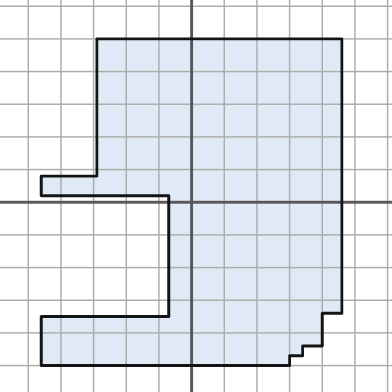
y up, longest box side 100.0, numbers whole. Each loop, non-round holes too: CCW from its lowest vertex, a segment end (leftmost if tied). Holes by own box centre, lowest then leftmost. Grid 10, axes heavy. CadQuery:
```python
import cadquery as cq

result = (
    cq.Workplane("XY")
    .moveTo(-46.0, -50.0)
    .lineTo(30.0, -50.0)
    .lineTo(30.0, -47.0)
    .lineTo(34.0, -47.0)
    .lineTo(34.0, -44.0)
    .lineTo(40.0, -44.0)
    .lineTo(40.0, -34.0)
    .lineTo(46.0, -34.0)
    .lineTo(46.0, 50.0)
    .lineTo(-29.0, 50.0)
    .lineTo(-29.0, 8.0)
    .lineTo(-46.0, 8.0)
    .lineTo(-46.0, 2.0)
    .lineTo(-7.0, 2.0)
    .lineTo(-7.0, -35.0)
    .lineTo(-46.0, -35.0)
    .close()
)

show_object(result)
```